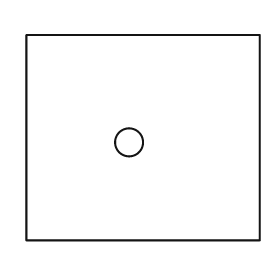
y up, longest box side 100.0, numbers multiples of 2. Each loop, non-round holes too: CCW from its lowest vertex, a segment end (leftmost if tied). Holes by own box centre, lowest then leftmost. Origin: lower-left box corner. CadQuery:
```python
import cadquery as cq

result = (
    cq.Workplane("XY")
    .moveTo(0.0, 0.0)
    .lineTo(100.0, 0.0)
    .lineTo(100.0, 88.0)
    .lineTo(0.0, 88.0)
    .close()
    .moveTo(44.0, 42.0)
    .circle(6.0)
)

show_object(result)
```